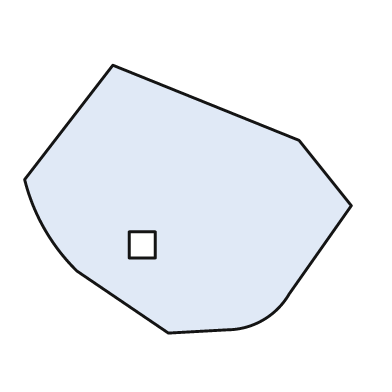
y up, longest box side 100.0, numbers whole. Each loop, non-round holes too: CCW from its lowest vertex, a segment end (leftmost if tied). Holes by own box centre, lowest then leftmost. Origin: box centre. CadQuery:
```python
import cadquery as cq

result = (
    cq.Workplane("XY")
    .moveTo(-6.0, -41.0)
    .lineTo(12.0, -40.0)
    .threePointArc((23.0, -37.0), (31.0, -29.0))
    .lineTo(50.0, -2.0)
    .lineTo(34.0, 18.0)
    .lineTo(-23.0, 41.0)
    .lineTo(-50.0, 6.0)
    .threePointArc((-44.0, -9.0), (-34.0, -22.0))
    .close()
    .moveTo(-18.0, -18.0)
    .lineTo(-10.0, -18.0)
    .lineTo(-10.0, -10.0)
    .lineTo(-18.0, -10.0)
    .close()
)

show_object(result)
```